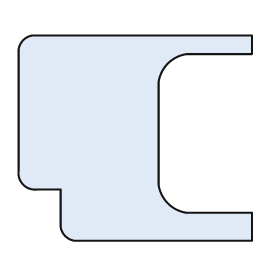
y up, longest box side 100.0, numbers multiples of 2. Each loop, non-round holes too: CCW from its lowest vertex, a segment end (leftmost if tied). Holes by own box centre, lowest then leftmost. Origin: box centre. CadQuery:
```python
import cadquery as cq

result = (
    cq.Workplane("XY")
    .moveTo(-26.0, -44.0)
    .lineTo(50.0, -44.0)
    .lineTo(50.0, -32.0)
    .lineTo(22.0, -32.0)
    .threePointArc((14.0, -28.0), (10.0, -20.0))
    .lineTo(10.0, 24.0)
    .threePointArc((14.0, 32.0), (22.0, 36.0))
    .lineTo(50.0, 36.0)
    .lineTo(50.0, 44.0)
    .lineTo(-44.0, 44.0)
    .threePointArc((-48.0, 42.0), (-50.0, 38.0))
    .lineTo(-50.0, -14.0)
    .threePointArc((-48.0, -20.0), (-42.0, -22.0))
    .lineTo(-32.0, -22.0)
    .lineTo(-32.0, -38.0)
    .threePointArc((-30.0, -42.0), (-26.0, -44.0))
    .close()
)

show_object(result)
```